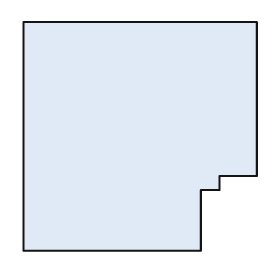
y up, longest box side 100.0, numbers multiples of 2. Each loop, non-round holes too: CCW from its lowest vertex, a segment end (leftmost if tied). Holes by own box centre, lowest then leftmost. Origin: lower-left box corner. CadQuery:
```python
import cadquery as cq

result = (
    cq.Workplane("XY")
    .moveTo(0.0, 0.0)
    .lineTo(76.0, 0.0)
    .lineTo(76.0, 26.0)
    .lineTo(84.0, 26.0)
    .lineTo(84.0, 32.0)
    .lineTo(100.0, 32.0)
    .lineTo(100.0, 98.0)
    .lineTo(0.0, 98.0)
    .close()
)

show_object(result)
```